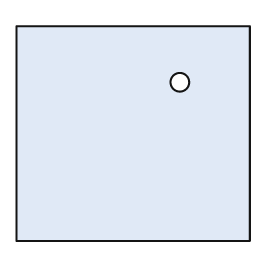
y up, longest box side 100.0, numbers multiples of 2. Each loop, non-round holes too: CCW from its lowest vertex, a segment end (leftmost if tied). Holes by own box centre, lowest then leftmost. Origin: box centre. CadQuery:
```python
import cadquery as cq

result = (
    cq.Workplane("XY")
    .moveTo(-50.0, -46.0)
    .lineTo(50.0, -46.0)
    .lineTo(50.0, 46.0)
    .lineTo(-50.0, 46.0)
    .close()
    .moveTo(20.0, 22.0)
    .circle(4.0)
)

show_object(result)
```